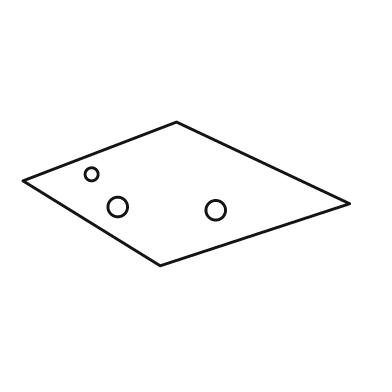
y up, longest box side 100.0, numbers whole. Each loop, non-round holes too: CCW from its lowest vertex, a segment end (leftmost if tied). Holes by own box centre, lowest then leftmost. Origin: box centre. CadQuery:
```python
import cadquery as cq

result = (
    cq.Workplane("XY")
    .moveTo(-8.0, -22.0)
    .lineTo(50.0, -3.0)
    .lineTo(-3.0, 22.0)
    .lineTo(-50.0, 4.0)
    .close()
    .moveTo(9.0, -5.0)
    .circle(3.0)
    .moveTo(-21.0, -4.0)
    .circle(3.0)
    .moveTo(-29.0, 6.0)
    .circle(2.0)
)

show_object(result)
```